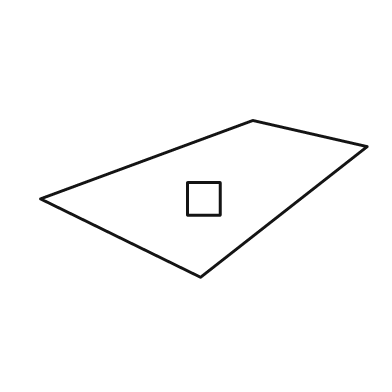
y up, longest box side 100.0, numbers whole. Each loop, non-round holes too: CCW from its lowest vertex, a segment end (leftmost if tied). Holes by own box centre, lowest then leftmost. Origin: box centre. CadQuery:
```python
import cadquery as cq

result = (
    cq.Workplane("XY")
    .moveTo(-1.0, -24.0)
    .lineTo(50.0, 16.0)
    .lineTo(15.0, 24.0)
    .lineTo(-50.0, 0.0)
    .close()
    .moveTo(-5.0, -5.0)
    .lineTo(5.0, -5.0)
    .lineTo(5.0, 5.0)
    .lineTo(-5.0, 5.0)
    .close()
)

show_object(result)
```